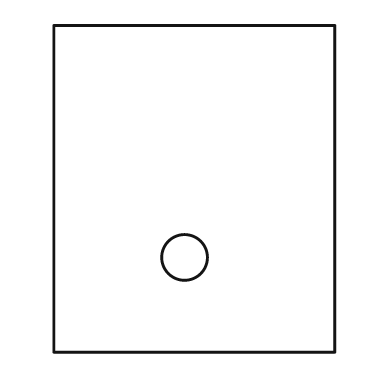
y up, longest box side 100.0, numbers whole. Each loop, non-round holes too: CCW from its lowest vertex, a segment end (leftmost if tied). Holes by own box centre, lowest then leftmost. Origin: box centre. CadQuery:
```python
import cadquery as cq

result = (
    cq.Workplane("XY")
    .moveTo(-43.0, -50.0)
    .lineTo(43.0, -50.0)
    .lineTo(43.0, 50.0)
    .lineTo(-43.0, 50.0)
    .close()
    .moveTo(-3.0, -21.0)
    .circle(7.0)
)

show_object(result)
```